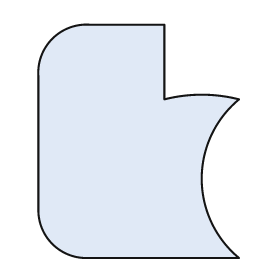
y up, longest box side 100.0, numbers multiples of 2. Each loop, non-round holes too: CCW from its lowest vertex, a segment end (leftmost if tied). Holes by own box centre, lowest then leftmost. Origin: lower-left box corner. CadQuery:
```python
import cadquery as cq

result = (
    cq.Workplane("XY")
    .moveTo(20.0, 0.0)
    .lineTo(86.0, 0.0)
    .threePointArc((70.0, 34.0), (86.0, 68.0))
    .threePointArc((70.0, 70.0), (54.0, 68.0))
    .lineTo(54.0, 100.0)
    .lineTo(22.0, 100.0)
    .threePointArc((6.0, 94.0), (0.0, 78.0))
    .lineTo(0.0, 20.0)
    .threePointArc((6.0, 6.0), (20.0, 0.0))
    .close()
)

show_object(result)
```